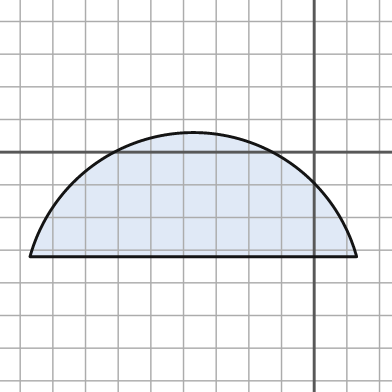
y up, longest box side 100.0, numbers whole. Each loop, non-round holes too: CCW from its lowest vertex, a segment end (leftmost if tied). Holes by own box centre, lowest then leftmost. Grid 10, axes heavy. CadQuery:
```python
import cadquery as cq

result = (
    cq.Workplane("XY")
    .moveTo(-87.0, -32.0)
    .lineTo(13.0, -32.0)
    .threePointArc((-37.0, 6.0), (-87.0, -32.0))
    .close()
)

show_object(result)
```